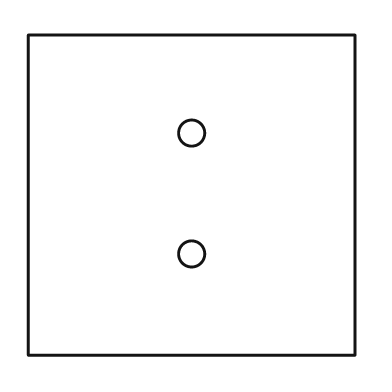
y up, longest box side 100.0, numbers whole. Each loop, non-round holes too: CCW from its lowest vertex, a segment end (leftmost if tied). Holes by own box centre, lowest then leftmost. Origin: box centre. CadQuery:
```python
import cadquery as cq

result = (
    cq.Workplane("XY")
    .moveTo(-50.0, -49.0)
    .lineTo(50.0, -49.0)
    .lineTo(50.0, 49.0)
    .lineTo(-50.0, 49.0)
    .close()
    .moveTo(0.0, -18.0)
    .circle(4.0)
    .moveTo(0.0, 19.0)
    .circle(4.0)
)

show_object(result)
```